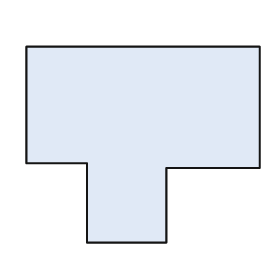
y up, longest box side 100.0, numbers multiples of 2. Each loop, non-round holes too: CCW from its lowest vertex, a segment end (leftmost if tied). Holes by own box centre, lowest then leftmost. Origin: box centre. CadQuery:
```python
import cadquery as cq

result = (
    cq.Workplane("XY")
    .moveTo(-24.0, -42.0)
    .lineTo(10.0, -42.0)
    .lineTo(10.0, -10.0)
    .lineTo(50.0, -10.0)
    .lineTo(50.0, 42.0)
    .lineTo(-50.0, 42.0)
    .lineTo(-50.0, -8.0)
    .lineTo(-24.0, -8.0)
    .close()
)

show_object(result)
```